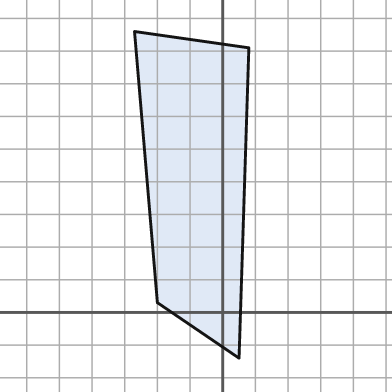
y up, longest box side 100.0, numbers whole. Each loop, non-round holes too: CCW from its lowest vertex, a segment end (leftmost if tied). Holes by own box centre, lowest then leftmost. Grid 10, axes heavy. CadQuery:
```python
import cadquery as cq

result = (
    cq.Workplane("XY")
    .moveTo(5.0, -14.0)
    .lineTo(8.0, 81.0)
    .lineTo(-27.0, 86.0)
    .lineTo(-20.0, 3.0)
    .close()
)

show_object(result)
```